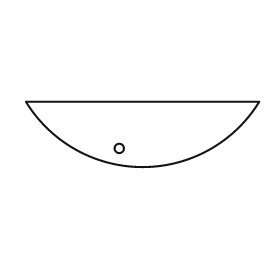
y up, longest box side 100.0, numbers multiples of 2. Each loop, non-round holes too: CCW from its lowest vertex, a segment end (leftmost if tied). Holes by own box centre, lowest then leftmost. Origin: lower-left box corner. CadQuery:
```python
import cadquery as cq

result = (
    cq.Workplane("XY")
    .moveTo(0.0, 28.0)
    .threePointArc((50.0, 0.0), (100.0, 28.0))
    .close()
    .moveTo(40.0, 8.0)
    .circle(2.0)
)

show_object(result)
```